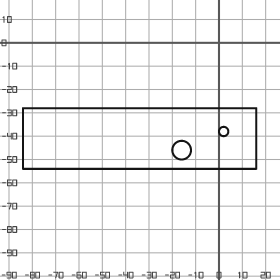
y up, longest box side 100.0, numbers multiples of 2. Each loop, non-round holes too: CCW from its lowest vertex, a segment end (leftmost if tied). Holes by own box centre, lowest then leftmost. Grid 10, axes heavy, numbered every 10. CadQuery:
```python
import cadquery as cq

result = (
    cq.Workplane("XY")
    .moveTo(-84.0, -54.0)
    .lineTo(16.0, -54.0)
    .lineTo(16.0, -28.0)
    .lineTo(-84.0, -28.0)
    .close()
    .moveTo(-16.0, -46.0)
    .circle(4.0)
    .moveTo(2.0, -38.0)
    .circle(2.0)
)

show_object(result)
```